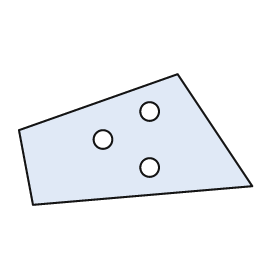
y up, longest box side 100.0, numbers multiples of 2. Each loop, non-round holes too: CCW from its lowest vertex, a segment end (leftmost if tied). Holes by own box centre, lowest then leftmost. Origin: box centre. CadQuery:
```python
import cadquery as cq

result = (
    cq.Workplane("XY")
    .moveTo(-44.0, -28.0)
    .lineTo(50.0, -20.0)
    .lineTo(18.0, 28.0)
    .lineTo(-50.0, 4.0)
    .close()
    .moveTo(6.0, -12.0)
    .circle(4.0)
    .moveTo(-14.0, 0.0)
    .circle(4.0)
    .moveTo(6.0, 12.0)
    .circle(4.0)
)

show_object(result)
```